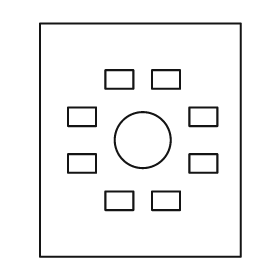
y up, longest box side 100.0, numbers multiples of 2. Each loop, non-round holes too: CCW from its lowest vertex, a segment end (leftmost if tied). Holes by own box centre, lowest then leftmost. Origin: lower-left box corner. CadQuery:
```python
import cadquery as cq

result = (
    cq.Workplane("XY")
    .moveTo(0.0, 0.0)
    .lineTo(86.0, 0.0)
    .lineTo(86.0, 100.0)
    .lineTo(0.0, 100.0)
    .close()
    .moveTo(28.0, 20.0)
    .lineTo(40.0, 20.0)
    .lineTo(40.0, 28.0)
    .lineTo(28.0, 28.0)
    .close()
    .moveTo(48.0, 20.0)
    .lineTo(60.0, 20.0)
    .lineTo(60.0, 28.0)
    .lineTo(48.0, 28.0)
    .close()
    .moveTo(12.0, 36.0)
    .lineTo(24.0, 36.0)
    .lineTo(24.0, 44.0)
    .lineTo(12.0, 44.0)
    .close()
    .moveTo(64.0, 36.0)
    .lineTo(76.0, 36.0)
    .lineTo(76.0, 44.0)
    .lineTo(64.0, 44.0)
    .close()
    .moveTo(44.0, 50.0)
    .circle(12.0)
    .moveTo(12.0, 56.0)
    .lineTo(24.0, 56.0)
    .lineTo(24.0, 64.0)
    .lineTo(12.0, 64.0)
    .close()
    .moveTo(64.0, 56.0)
    .lineTo(76.0, 56.0)
    .lineTo(76.0, 64.0)
    .lineTo(64.0, 64.0)
    .close()
    .moveTo(28.0, 72.0)
    .lineTo(40.0, 72.0)
    .lineTo(40.0, 80.0)
    .lineTo(28.0, 80.0)
    .close()
    .moveTo(48.0, 72.0)
    .lineTo(60.0, 72.0)
    .lineTo(60.0, 80.0)
    .lineTo(48.0, 80.0)
    .close()
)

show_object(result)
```